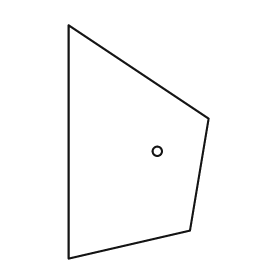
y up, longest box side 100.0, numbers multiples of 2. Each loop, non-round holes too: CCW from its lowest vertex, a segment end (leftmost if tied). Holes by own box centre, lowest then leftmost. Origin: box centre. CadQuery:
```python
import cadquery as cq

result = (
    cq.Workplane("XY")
    .moveTo(-30.0, -50.0)
    .lineTo(22.0, -38.0)
    .lineTo(30.0, 10.0)
    .lineTo(-30.0, 50.0)
    .close()
    .moveTo(8.0, -4.0)
    .circle(2.0)
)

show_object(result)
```